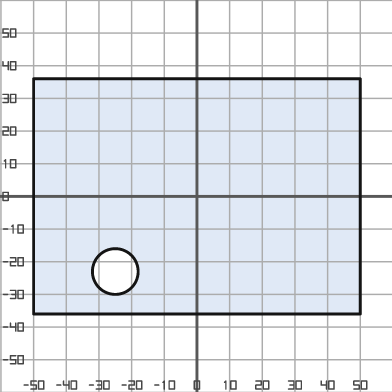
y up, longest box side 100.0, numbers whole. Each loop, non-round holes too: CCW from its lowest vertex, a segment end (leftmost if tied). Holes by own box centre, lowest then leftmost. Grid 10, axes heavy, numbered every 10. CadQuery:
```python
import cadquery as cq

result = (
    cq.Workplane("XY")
    .moveTo(-50.0, -36.0)
    .lineTo(50.0, -36.0)
    .lineTo(50.0, 36.0)
    .lineTo(-50.0, 36.0)
    .close()
    .moveTo(-25.0, -23.0)
    .circle(7.0)
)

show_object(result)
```